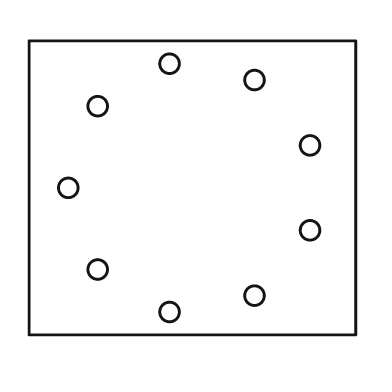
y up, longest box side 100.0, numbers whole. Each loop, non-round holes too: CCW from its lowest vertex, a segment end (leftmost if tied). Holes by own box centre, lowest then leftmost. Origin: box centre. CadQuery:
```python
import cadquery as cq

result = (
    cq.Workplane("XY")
    .moveTo(-50.0, -45.0)
    .lineTo(50.0, -45.0)
    .lineTo(50.0, 45.0)
    .lineTo(-50.0, 45.0)
    .close()
    .moveTo(-7.0, -38.0)
    .circle(3.0)
    .moveTo(19.0, -33.0)
    .circle(3.0)
    .moveTo(-29.0, -25.0)
    .circle(3.0)
    .moveTo(36.0, -13.0)
    .circle(3.0)
    .moveTo(-38.0, 0.0)
    .circle(3.0)
    .moveTo(36.0, 13.0)
    .circle(3.0)
    .moveTo(-29.0, 25.0)
    .circle(3.0)
    .moveTo(19.0, 33.0)
    .circle(3.0)
    .moveTo(-7.0, 38.0)
    .circle(3.0)
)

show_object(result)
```